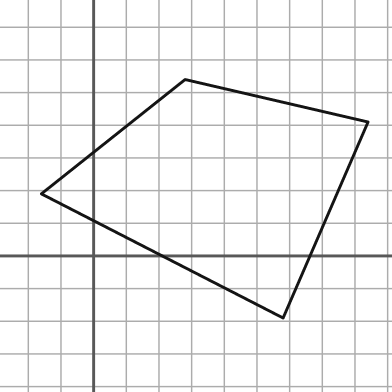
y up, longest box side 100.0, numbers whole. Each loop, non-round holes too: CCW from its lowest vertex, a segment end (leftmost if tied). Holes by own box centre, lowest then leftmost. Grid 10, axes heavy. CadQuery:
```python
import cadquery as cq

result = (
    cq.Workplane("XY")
    .moveTo(58.0, -19.0)
    .lineTo(84.0, 41.0)
    .lineTo(28.0, 54.0)
    .lineTo(-16.0, 19.0)
    .close()
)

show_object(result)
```